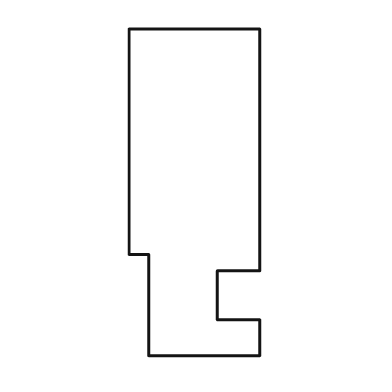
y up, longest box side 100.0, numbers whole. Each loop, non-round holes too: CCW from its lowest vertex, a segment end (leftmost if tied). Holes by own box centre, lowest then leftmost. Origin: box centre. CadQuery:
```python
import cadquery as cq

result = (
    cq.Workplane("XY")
    .moveTo(-14.0, -50.0)
    .lineTo(20.0, -50.0)
    .lineTo(20.0, -39.0)
    .lineTo(7.0, -39.0)
    .lineTo(7.0, -24.0)
    .lineTo(20.0, -24.0)
    .lineTo(20.0, 50.0)
    .lineTo(-20.0, 50.0)
    .lineTo(-20.0, -19.0)
    .lineTo(-14.0, -19.0)
    .close()
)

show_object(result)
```